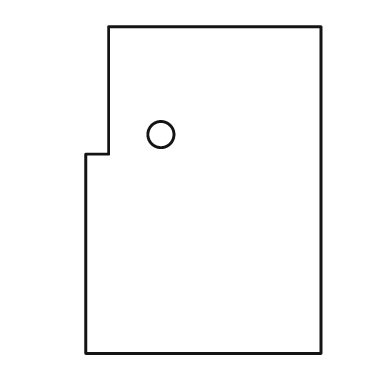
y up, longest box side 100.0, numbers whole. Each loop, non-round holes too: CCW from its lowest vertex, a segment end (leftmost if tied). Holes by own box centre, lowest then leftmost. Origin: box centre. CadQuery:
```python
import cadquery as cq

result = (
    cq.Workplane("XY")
    .moveTo(-36.0, -50.0)
    .lineTo(36.0, -50.0)
    .lineTo(36.0, 50.0)
    .lineTo(-29.0, 50.0)
    .lineTo(-29.0, 11.0)
    .lineTo(-36.0, 11.0)
    .close()
    .moveTo(-13.0, 17.0)
    .circle(4.0)
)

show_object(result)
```